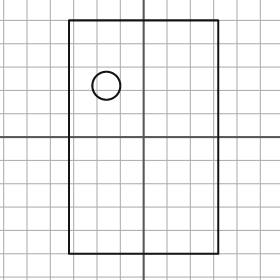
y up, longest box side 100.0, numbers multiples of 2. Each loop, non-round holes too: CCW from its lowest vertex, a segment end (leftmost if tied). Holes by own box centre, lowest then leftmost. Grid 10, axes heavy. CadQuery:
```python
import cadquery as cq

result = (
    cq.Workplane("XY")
    .moveTo(-32.0, -50.0)
    .lineTo(32.0, -50.0)
    .lineTo(32.0, 50.0)
    .lineTo(-32.0, 50.0)
    .close()
    .moveTo(-16.0, 22.0)
    .circle(6.0)
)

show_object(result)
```